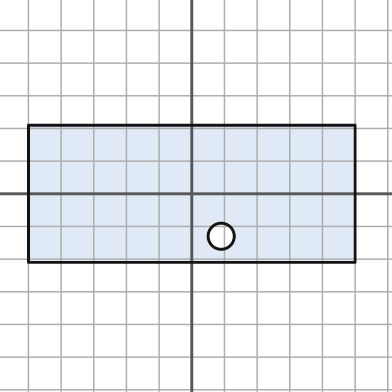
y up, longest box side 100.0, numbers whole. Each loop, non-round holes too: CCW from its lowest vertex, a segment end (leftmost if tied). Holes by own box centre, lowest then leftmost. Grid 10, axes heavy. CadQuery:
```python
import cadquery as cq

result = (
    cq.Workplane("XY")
    .moveTo(-50.0, -21.0)
    .lineTo(50.0, -21.0)
    .lineTo(50.0, 21.0)
    .lineTo(-50.0, 21.0)
    .close()
    .moveTo(9.0, -13.0)
    .circle(4.0)
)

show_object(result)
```